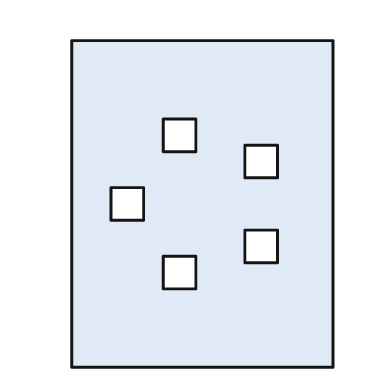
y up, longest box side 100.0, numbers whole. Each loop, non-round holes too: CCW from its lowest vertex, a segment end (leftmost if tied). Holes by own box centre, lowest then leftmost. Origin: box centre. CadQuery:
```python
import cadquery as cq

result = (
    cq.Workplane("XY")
    .moveTo(-40.0, -50.0)
    .lineTo(40.0, -50.0)
    .lineTo(40.0, 50.0)
    .lineTo(-40.0, 50.0)
    .close()
    .moveTo(-12.0, -26.0)
    .lineTo(-2.0, -26.0)
    .lineTo(-2.0, -16.0)
    .lineTo(-12.0, -16.0)
    .close()
    .moveTo(13.0, -18.0)
    .lineTo(23.0, -18.0)
    .lineTo(23.0, -8.0)
    .lineTo(13.0, -8.0)
    .close()
    .moveTo(-28.0, -5.0)
    .lineTo(-18.0, -5.0)
    .lineTo(-18.0, 5.0)
    .lineTo(-28.0, 5.0)
    .close()
    .moveTo(13.0, 8.0)
    .lineTo(23.0, 8.0)
    .lineTo(23.0, 18.0)
    .lineTo(13.0, 18.0)
    .close()
    .moveTo(-12.0, 16.0)
    .lineTo(-2.0, 16.0)
    .lineTo(-2.0, 26.0)
    .lineTo(-12.0, 26.0)
    .close()
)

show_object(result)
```